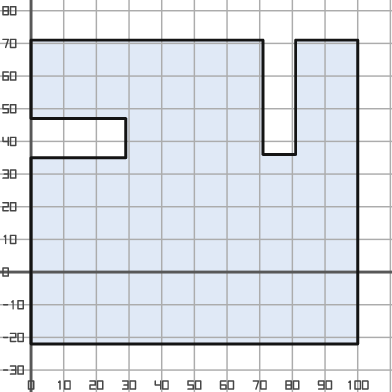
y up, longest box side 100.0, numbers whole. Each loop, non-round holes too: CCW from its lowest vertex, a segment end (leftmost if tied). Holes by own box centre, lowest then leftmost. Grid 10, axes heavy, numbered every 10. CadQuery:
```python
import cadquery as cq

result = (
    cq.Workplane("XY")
    .moveTo(0.0, -22.0)
    .lineTo(100.0, -22.0)
    .lineTo(100.0, 71.0)
    .lineTo(81.0, 71.0)
    .lineTo(81.0, 36.0)
    .lineTo(71.0, 36.0)
    .lineTo(71.0, 71.0)
    .lineTo(0.0, 71.0)
    .lineTo(0.0, 47.0)
    .lineTo(29.0, 47.0)
    .lineTo(29.0, 35.0)
    .lineTo(0.0, 35.0)
    .close()
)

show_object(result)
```